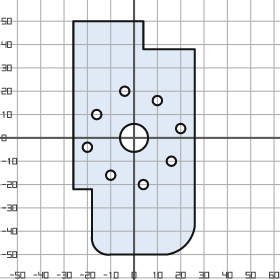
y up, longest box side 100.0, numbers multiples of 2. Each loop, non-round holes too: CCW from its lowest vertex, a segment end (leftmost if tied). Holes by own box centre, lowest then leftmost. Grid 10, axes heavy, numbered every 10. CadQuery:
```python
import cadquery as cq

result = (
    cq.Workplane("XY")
    .moveTo(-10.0, -50.0)
    .lineTo(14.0, -50.0)
    .threePointArc((22.0, -46.0), (26.0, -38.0))
    .lineTo(26.0, 38.0)
    .lineTo(4.0, 38.0)
    .lineTo(4.0, 50.0)
    .lineTo(-26.0, 50.0)
    .lineTo(-26.0, -22.0)
    .lineTo(-18.0, -22.0)
    .lineTo(-18.0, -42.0)
    .threePointArc((-16.0, -48.0), (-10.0, -50.0))
    .close()
    .moveTo(4.0, -20.0)
    .circle(2.0)
    .moveTo(-10.0, -16.0)
    .circle(2.0)
    .moveTo(16.0, -10.0)
    .circle(2.0)
    .moveTo(-20.0, -4.0)
    .circle(2.0)
    .moveTo(0.0, 0.0)
    .circle(6.0)
    .moveTo(20.0, 4.0)
    .circle(2.0)
    .moveTo(-16.0, 10.0)
    .circle(2.0)
    .moveTo(10.0, 16.0)
    .circle(2.0)
    .moveTo(-4.0, 20.0)
    .circle(2.0)
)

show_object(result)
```